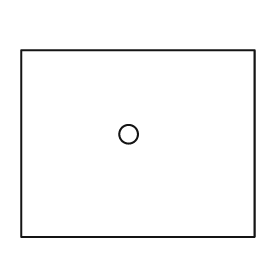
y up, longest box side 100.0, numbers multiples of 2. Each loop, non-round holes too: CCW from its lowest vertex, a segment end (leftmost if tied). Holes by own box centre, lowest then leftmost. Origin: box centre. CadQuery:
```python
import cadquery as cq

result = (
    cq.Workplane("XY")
    .moveTo(-50.0, -40.0)
    .lineTo(50.0, -40.0)
    .lineTo(50.0, 40.0)
    .lineTo(-50.0, 40.0)
    .close()
    .moveTo(-4.0, 4.0)
    .circle(4.0)
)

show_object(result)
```